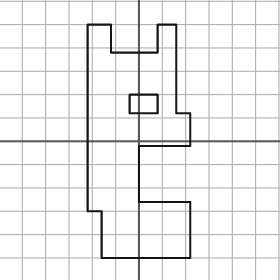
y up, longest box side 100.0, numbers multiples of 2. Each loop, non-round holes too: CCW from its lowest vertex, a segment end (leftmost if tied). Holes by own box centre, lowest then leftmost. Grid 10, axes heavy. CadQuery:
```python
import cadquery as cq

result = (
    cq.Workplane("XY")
    .moveTo(-16.0, -50.0)
    .lineTo(22.0, -50.0)
    .lineTo(22.0, -26.0)
    .lineTo(0.0, -26.0)
    .lineTo(0.0, -2.0)
    .lineTo(22.0, -2.0)
    .lineTo(22.0, 12.0)
    .lineTo(16.0, 12.0)
    .lineTo(16.0, 50.0)
    .lineTo(8.0, 50.0)
    .lineTo(8.0, 38.0)
    .lineTo(-12.0, 38.0)
    .lineTo(-12.0, 50.0)
    .lineTo(-22.0, 50.0)
    .lineTo(-22.0, -30.0)
    .lineTo(-16.0, -30.0)
    .close()
    .moveTo(-4.0, 12.0)
    .lineTo(8.0, 12.0)
    .lineTo(8.0, 20.0)
    .lineTo(-4.0, 20.0)
    .close()
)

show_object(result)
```